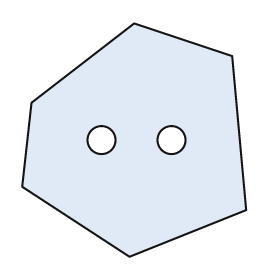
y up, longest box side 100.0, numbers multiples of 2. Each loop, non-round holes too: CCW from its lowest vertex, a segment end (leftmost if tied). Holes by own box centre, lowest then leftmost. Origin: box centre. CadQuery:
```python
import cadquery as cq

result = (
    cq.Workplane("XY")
    .moveTo(-2.0, -50.0)
    .lineTo(48.0, -30.0)
    .lineTo(42.0, 36.0)
    .lineTo(0.0, 50.0)
    .lineTo(-44.0, 16.0)
    .lineTo(-48.0, -20.0)
    .close()
    .moveTo(-14.0, 0.0)
    .circle(6.0)
    .moveTo(16.0, 0.0)
    .circle(6.0)
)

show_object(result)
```